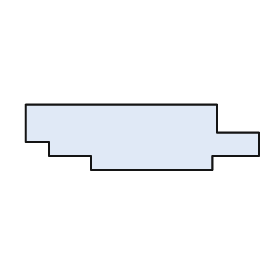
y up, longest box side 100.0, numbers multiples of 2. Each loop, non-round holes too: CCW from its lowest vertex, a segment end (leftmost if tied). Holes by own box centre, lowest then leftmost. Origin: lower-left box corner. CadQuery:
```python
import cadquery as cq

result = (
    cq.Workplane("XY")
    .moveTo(28.0, 0.0)
    .lineTo(80.0, 0.0)
    .lineTo(80.0, 6.0)
    .lineTo(100.0, 6.0)
    .lineTo(100.0, 16.0)
    .lineTo(82.0, 16.0)
    .lineTo(82.0, 28.0)
    .lineTo(0.0, 28.0)
    .lineTo(0.0, 12.0)
    .lineTo(10.0, 12.0)
    .lineTo(10.0, 6.0)
    .lineTo(28.0, 6.0)
    .close()
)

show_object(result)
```